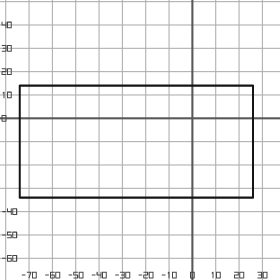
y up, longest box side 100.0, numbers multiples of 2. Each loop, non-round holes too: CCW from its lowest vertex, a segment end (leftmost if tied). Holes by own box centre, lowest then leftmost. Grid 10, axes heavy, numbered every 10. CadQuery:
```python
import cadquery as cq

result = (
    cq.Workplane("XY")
    .moveTo(-74.0, -34.0)
    .lineTo(26.0, -34.0)
    .lineTo(26.0, 14.0)
    .lineTo(-74.0, 14.0)
    .close()
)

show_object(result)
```